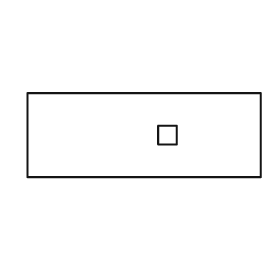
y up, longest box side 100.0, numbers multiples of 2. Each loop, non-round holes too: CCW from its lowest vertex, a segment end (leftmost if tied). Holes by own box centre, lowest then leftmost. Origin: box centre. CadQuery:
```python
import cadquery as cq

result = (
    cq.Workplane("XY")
    .moveTo(-50.0, -18.0)
    .lineTo(50.0, -18.0)
    .lineTo(50.0, 18.0)
    .lineTo(-50.0, 18.0)
    .close()
    .moveTo(6.0, -4.0)
    .lineTo(14.0, -4.0)
    .lineTo(14.0, 4.0)
    .lineTo(6.0, 4.0)
    .close()
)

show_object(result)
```